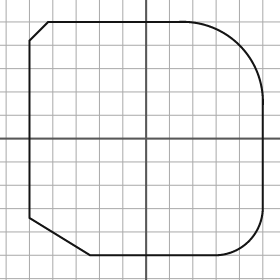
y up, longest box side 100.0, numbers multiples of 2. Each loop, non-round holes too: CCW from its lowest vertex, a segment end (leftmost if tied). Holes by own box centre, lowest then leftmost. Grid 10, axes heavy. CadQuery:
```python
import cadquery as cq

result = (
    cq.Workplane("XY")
    .moveTo(-24.0, -50.0)
    .lineTo(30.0, -50.0)
    .threePointArc((44.0, -44.0), (50.0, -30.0))
    .lineTo(50.0, 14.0)
    .threePointArc((40.0, 40.0), (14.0, 50.0))
    .lineTo(-42.0, 50.0)
    .lineTo(-50.0, 42.0)
    .lineTo(-50.0, -34.0)
    .close()
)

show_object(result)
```